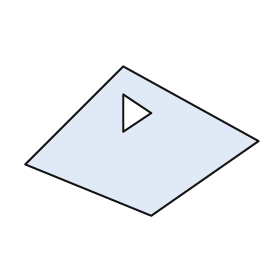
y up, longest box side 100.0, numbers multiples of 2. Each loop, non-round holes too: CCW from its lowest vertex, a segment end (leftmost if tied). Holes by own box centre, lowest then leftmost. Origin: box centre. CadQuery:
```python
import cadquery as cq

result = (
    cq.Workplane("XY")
    .moveTo(4.0, -32.0)
    .lineTo(50.0, 0.0)
    .lineTo(-8.0, 32.0)
    .lineTo(-50.0, -10.0)
    .close()
    .moveTo(-8.0, 4.0)
    .lineTo(4.0, 12.0)
    .lineTo(-8.0, 20.0)
    .close()
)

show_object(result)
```